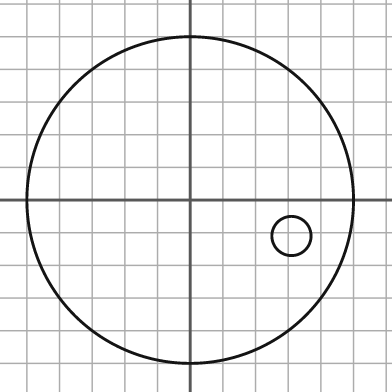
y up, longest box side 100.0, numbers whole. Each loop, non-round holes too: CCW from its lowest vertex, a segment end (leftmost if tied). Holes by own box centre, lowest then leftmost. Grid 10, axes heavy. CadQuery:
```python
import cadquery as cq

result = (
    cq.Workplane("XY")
    .moveTo(0.0, 0.0)
    .circle(50.0)
    .moveTo(31.0, -11.0)
    .circle(6.0)
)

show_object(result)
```